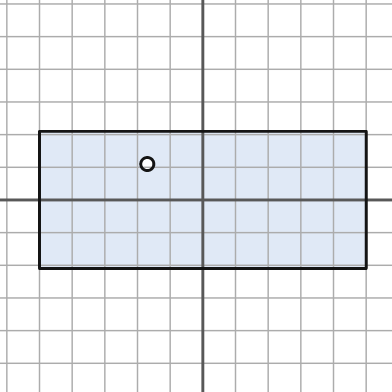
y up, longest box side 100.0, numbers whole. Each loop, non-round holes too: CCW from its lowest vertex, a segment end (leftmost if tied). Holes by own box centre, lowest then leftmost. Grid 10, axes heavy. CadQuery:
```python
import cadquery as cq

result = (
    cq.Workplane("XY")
    .moveTo(-50.0, -21.0)
    .lineTo(50.0, -21.0)
    .lineTo(50.0, 21.0)
    .lineTo(-50.0, 21.0)
    .close()
    .moveTo(-17.0, 11.0)
    .circle(2.0)
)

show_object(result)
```